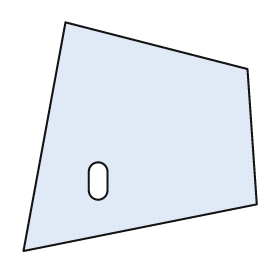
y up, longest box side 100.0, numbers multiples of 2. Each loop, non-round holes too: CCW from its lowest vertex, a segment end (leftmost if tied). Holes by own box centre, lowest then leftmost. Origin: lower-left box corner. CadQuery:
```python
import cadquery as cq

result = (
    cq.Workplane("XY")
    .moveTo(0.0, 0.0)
    .lineTo(100.0, 20.0)
    .lineTo(96.0, 78.0)
    .lineTo(18.0, 98.0)
    .close()
    .moveTo(28.0, 26.0)
    .threePointArc((32.0, 22.0), (36.0, 26.0))
    .lineTo(36.0, 34.0)
    .threePointArc((32.0, 38.0), (28.0, 34.0))
    .close()
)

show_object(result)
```